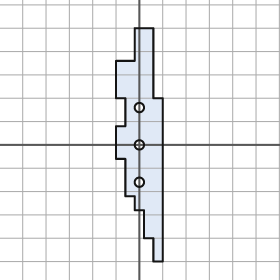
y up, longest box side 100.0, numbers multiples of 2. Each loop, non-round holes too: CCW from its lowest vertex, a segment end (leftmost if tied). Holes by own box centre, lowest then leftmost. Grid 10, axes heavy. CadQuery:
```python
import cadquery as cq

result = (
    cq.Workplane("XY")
    .moveTo(6.0, -50.0)
    .lineTo(10.0, -50.0)
    .lineTo(10.0, 20.0)
    .lineTo(6.0, 20.0)
    .lineTo(6.0, 50.0)
    .lineTo(-2.0, 50.0)
    .lineTo(-2.0, 36.0)
    .lineTo(-10.0, 36.0)
    .lineTo(-10.0, 20.0)
    .lineTo(-6.0, 20.0)
    .lineTo(-6.0, 8.0)
    .lineTo(-10.0, 8.0)
    .lineTo(-10.0, -6.0)
    .lineTo(-6.0, -6.0)
    .lineTo(-6.0, -22.0)
    .lineTo(-2.0, -22.0)
    .lineTo(-2.0, -28.0)
    .lineTo(2.0, -28.0)
    .lineTo(2.0, -40.0)
    .lineTo(6.0, -40.0)
    .close()
    .moveTo(0.0, -16.0)
    .circle(2.0)
    .moveTo(0.0, 0.0)
    .circle(2.0)
    .moveTo(0.0, 16.0)
    .circle(2.0)
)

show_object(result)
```